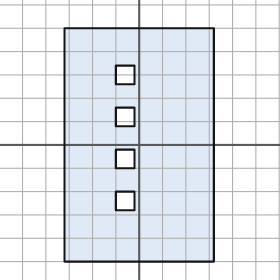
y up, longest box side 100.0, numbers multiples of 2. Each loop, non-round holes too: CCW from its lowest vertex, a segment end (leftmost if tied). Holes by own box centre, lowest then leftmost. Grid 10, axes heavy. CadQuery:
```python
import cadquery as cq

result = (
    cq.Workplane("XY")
    .moveTo(-32.0, -50.0)
    .lineTo(32.0, -50.0)
    .lineTo(32.0, 50.0)
    .lineTo(-32.0, 50.0)
    .close()
    .moveTo(-10.0, -28.0)
    .lineTo(-2.0, -28.0)
    .lineTo(-2.0, -20.0)
    .lineTo(-10.0, -20.0)
    .close()
    .moveTo(-10.0, -10.0)
    .lineTo(-2.0, -10.0)
    .lineTo(-2.0, -2.0)
    .lineTo(-10.0, -2.0)
    .close()
    .moveTo(-10.0, 8.0)
    .lineTo(-2.0, 8.0)
    .lineTo(-2.0, 16.0)
    .lineTo(-10.0, 16.0)
    .close()
    .moveTo(-10.0, 26.0)
    .lineTo(-2.0, 26.0)
    .lineTo(-2.0, 34.0)
    .lineTo(-10.0, 34.0)
    .close()
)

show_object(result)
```